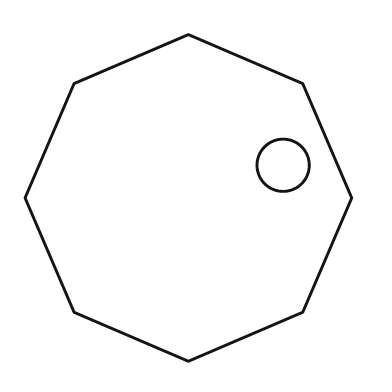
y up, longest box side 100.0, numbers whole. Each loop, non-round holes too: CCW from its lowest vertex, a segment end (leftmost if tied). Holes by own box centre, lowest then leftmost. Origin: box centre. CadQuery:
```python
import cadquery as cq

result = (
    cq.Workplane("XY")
    .moveTo(0.0, -50.0)
    .lineTo(35.0, -35.0)
    .lineTo(50.0, 0.0)
    .lineTo(35.0, 35.0)
    .lineTo(0.0, 50.0)
    .lineTo(-35.0, 35.0)
    .lineTo(-50.0, 0.0)
    .lineTo(-35.0, -35.0)
    .close()
    .moveTo(29.0, 10.0)
    .circle(8.0)
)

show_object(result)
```